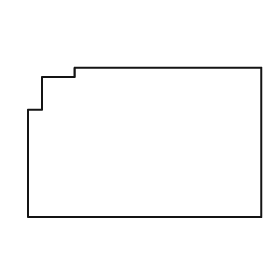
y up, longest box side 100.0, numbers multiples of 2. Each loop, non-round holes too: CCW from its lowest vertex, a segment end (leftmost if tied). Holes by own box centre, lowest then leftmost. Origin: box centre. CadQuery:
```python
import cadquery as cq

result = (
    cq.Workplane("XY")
    .moveTo(-50.0, -32.0)
    .lineTo(50.0, -32.0)
    .lineTo(50.0, 32.0)
    .lineTo(-30.0, 32.0)
    .lineTo(-30.0, 28.0)
    .lineTo(-44.0, 28.0)
    .lineTo(-44.0, 14.0)
    .lineTo(-50.0, 14.0)
    .close()
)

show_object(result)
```